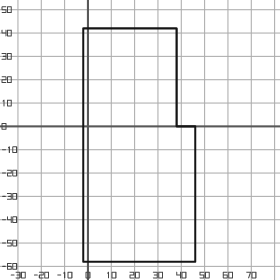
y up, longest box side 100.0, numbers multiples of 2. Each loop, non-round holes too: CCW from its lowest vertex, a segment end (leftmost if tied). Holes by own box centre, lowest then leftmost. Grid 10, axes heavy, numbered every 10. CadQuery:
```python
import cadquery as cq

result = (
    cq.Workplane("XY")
    .moveTo(-2.0, -58.0)
    .lineTo(46.0, -58.0)
    .lineTo(46.0, 0.0)
    .lineTo(38.0, 0.0)
    .lineTo(38.0, 42.0)
    .lineTo(-2.0, 42.0)
    .close()
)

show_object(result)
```